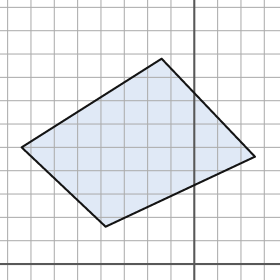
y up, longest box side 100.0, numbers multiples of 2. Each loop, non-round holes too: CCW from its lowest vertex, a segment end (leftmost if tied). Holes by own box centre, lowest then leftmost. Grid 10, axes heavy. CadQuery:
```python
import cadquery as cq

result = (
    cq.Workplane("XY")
    .moveTo(-38.0, 16.0)
    .lineTo(26.0, 46.0)
    .lineTo(-14.0, 88.0)
    .lineTo(-74.0, 50.0)
    .close()
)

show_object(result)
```